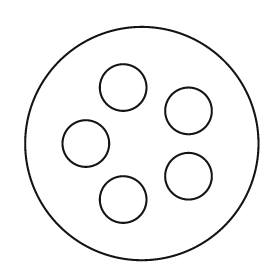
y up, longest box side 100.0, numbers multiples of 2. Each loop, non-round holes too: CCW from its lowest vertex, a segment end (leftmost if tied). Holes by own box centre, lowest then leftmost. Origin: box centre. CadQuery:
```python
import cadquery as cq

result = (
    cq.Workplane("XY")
    .moveTo(0.0, 0.0)
    .circle(50.0)
    .moveTo(-8.0, -24.0)
    .circle(10.0)
    .moveTo(20.0, -14.0)
    .circle(10.0)
    .moveTo(-24.0, 0.0)
    .circle(10.0)
    .moveTo(20.0, 14.0)
    .circle(10.0)
    .moveTo(-8.0, 24.0)
    .circle(10.0)
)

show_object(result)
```